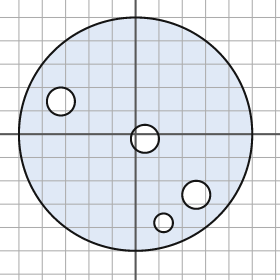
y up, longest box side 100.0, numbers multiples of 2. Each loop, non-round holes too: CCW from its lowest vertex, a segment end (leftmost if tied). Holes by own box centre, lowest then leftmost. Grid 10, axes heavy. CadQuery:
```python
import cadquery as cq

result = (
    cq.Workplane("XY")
    .moveTo(0.0, 0.0)
    .circle(50.0)
    .moveTo(12.0, -38.0)
    .circle(4.0)
    .moveTo(26.0, -26.0)
    .circle(6.0)
    .moveTo(4.0, -2.0)
    .circle(6.0)
    .moveTo(-32.0, 14.0)
    .circle(6.0)
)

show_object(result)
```